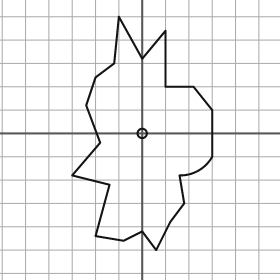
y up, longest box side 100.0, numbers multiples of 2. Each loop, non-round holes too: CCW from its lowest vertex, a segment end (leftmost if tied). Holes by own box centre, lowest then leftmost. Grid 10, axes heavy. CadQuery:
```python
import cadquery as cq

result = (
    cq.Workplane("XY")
    .moveTo(6.0, -50.0)
    .lineTo(12.0, -38.0)
    .lineTo(18.0, -30.0)
    .lineTo(16.0, -18.0)
    .threePointArc((24.0, -16.0), (30.0, -10.0))
    .lineTo(30.0, 10.0)
    .lineTo(22.0, 20.0)
    .lineTo(10.0, 20.0)
    .lineTo(10.0, 44.0)
    .lineTo(0.0, 32.0)
    .lineTo(-10.0, 50.0)
    .lineTo(-12.0, 30.0)
    .lineTo(-20.0, 24.0)
    .lineTo(-24.0, 12.0)
    .lineTo(-18.0, -4.0)
    .lineTo(-30.0, -18.0)
    .lineTo(-14.0, -22.0)
    .lineTo(-20.0, -44.0)
    .lineTo(-8.0, -46.0)
    .lineTo(0.0, -42.0)
    .close()
    .moveTo(0.0, 0.0)
    .circle(2.0)
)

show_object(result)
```